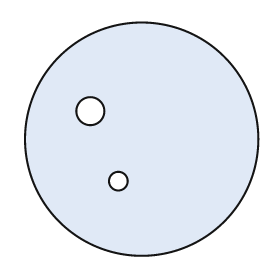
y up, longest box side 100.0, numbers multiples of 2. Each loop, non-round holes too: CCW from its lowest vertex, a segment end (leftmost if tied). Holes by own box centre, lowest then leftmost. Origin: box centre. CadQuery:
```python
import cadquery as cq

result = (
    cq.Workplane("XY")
    .moveTo(0.0, 0.0)
    .circle(50.0)
    .moveTo(-10.0, -18.0)
    .circle(4.0)
    .moveTo(-22.0, 12.0)
    .circle(6.0)
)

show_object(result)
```